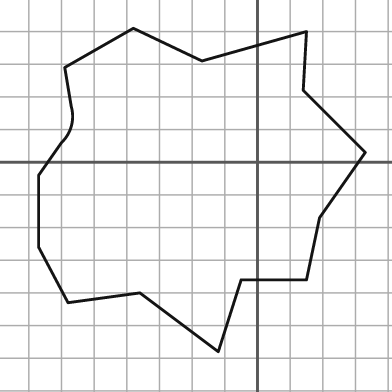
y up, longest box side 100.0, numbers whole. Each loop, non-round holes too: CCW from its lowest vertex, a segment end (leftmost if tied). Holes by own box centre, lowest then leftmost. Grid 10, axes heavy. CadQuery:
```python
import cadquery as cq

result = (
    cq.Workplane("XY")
    .moveTo(-12.0, -58.0)
    .lineTo(-5.0, -36.0)
    .lineTo(15.0, -36.0)
    .lineTo(19.0, -17.0)
    .lineTo(33.0, 3.0)
    .lineTo(14.0, 22.0)
    .lineTo(15.0, 40.0)
    .lineTo(-17.0, 31.0)
    .lineTo(-38.0, 41.0)
    .lineTo(-59.0, 29.0)
    .lineTo(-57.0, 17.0)
    .threePointArc((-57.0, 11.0), (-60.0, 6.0))
    .lineTo(-67.0, -4.0)
    .lineTo(-67.0, -26.0)
    .lineTo(-58.0, -43.0)
    .lineTo(-36.0, -40.0)
    .close()
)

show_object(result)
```